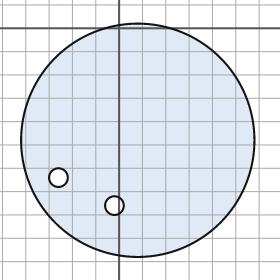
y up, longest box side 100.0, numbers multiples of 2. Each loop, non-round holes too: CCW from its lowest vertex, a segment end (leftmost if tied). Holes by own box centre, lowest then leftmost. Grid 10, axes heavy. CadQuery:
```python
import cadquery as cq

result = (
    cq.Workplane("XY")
    .moveTo(8.0, -48.0)
    .circle(50.0)
    .moveTo(-2.0, -76.0)
    .circle(4.0)
    .moveTo(-26.0, -64.0)
    .circle(4.0)
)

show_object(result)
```